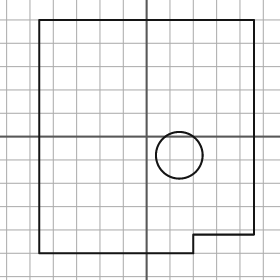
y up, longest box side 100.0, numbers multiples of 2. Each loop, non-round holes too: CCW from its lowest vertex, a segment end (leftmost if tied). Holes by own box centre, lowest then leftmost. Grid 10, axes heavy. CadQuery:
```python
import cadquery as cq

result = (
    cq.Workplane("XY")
    .moveTo(-46.0, -50.0)
    .lineTo(20.0, -50.0)
    .lineTo(20.0, -42.0)
    .lineTo(46.0, -42.0)
    .lineTo(46.0, 50.0)
    .lineTo(-46.0, 50.0)
    .close()
    .moveTo(14.0, -8.0)
    .circle(10.0)
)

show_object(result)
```